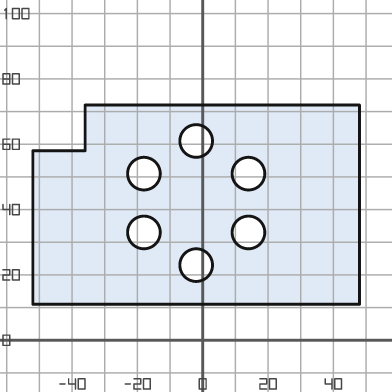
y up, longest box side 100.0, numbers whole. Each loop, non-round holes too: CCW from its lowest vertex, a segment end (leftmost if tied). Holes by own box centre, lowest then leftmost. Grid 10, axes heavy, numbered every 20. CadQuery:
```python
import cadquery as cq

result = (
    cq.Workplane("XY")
    .moveTo(-52.0, 11.0)
    .lineTo(48.0, 11.0)
    .lineTo(48.0, 72.0)
    .lineTo(-36.0, 72.0)
    .lineTo(-36.0, 58.0)
    .lineTo(-52.0, 58.0)
    .close()
    .moveTo(-2.0, 23.0)
    .circle(5.0)
    .moveTo(-18.0, 33.0)
    .circle(5.0)
    .moveTo(14.0, 33.0)
    .circle(5.0)
    .moveTo(-18.0, 51.0)
    .circle(5.0)
    .moveTo(14.0, 51.0)
    .circle(5.0)
    .moveTo(-2.0, 61.0)
    .circle(5.0)
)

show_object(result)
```